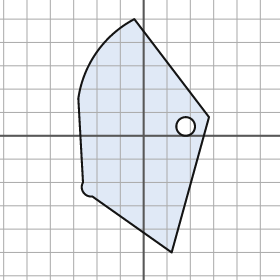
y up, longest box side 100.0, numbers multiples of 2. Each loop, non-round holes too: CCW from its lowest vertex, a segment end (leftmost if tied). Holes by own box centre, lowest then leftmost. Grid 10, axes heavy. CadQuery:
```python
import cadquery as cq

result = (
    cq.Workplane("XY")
    .moveTo(12.0, -50.0)
    .lineTo(28.0, 8.0)
    .lineTo(-4.0, 50.0)
    .threePointArc((-20.0, 36.0), (-28.0, 16.0))
    .lineTo(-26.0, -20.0)
    .threePointArc((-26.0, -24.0), (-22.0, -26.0))
    .close()
    .moveTo(18.0, 4.0)
    .circle(4.0)
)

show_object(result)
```